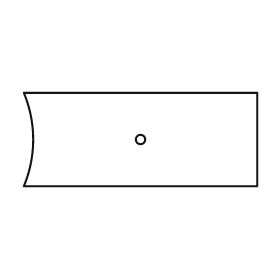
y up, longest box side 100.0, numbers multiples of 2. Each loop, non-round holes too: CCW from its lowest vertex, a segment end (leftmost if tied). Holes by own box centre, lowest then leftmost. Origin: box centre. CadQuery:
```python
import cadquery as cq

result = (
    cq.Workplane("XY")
    .moveTo(-50.0, -20.0)
    .lineTo(50.0, -20.0)
    .lineTo(50.0, 20.0)
    .lineTo(-50.0, 20.0)
    .threePointArc((-46.0, 0.0), (-50.0, -20.0))
    .close()
    .moveTo(0.0, 0.0)
    .circle(2.0)
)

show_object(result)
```